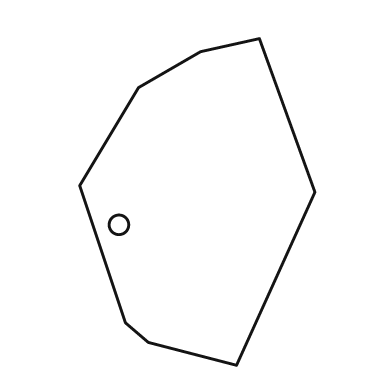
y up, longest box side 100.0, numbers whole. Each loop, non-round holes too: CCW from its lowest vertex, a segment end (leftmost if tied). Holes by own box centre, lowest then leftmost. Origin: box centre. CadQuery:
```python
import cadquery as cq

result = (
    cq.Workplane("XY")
    .moveTo(12.0, -50.0)
    .lineTo(36.0, 3.0)
    .lineTo(19.0, 50.0)
    .lineTo(1.0, 46.0)
    .lineTo(-18.0, 35.0)
    .lineTo(-36.0, 5.0)
    .lineTo(-22.0, -37.0)
    .lineTo(-15.0, -43.0)
    .close()
    .moveTo(-24.0, -7.0)
    .circle(3.0)
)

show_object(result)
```